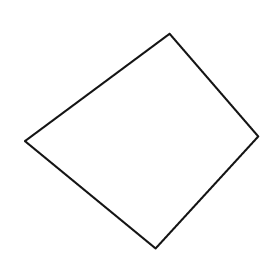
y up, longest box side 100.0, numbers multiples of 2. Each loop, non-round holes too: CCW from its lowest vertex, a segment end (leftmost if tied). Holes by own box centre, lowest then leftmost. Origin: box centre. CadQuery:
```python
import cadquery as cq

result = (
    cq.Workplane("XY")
    .moveTo(6.0, -46.0)
    .lineTo(50.0, 2.0)
    .lineTo(12.0, 46.0)
    .lineTo(-50.0, 0.0)
    .close()
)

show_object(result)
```